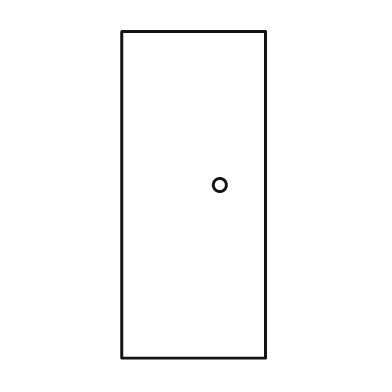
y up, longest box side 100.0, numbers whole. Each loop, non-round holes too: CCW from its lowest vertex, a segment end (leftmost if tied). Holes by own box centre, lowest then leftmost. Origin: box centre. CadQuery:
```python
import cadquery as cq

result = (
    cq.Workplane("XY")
    .moveTo(-22.0, -50.0)
    .lineTo(22.0, -50.0)
    .lineTo(22.0, 50.0)
    .lineTo(-22.0, 50.0)
    .close()
    .moveTo(8.0, 3.0)
    .circle(2.0)
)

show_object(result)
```